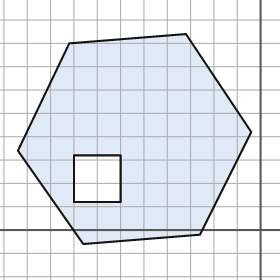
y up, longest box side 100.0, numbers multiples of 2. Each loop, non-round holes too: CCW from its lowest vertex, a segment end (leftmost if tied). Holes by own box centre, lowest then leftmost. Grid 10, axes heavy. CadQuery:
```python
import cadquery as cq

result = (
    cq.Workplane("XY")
    .moveTo(-76.0, -6.0)
    .lineTo(-26.0, -2.0)
    .lineTo(-4.0, 42.0)
    .lineTo(-32.0, 84.0)
    .lineTo(-82.0, 80.0)
    .lineTo(-104.0, 34.0)
    .close()
    .moveTo(-80.0, 12.0)
    .lineTo(-60.0, 12.0)
    .lineTo(-60.0, 32.0)
    .lineTo(-80.0, 32.0)
    .close()
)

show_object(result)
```